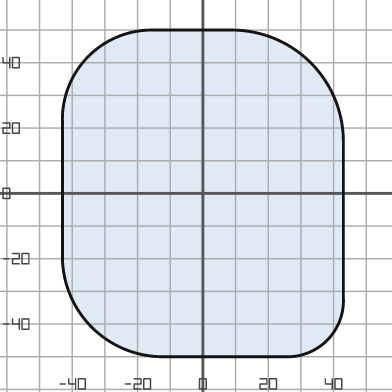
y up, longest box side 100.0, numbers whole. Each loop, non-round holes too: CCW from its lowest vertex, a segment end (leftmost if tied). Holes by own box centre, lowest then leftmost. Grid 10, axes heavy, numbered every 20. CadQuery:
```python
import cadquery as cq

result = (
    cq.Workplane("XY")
    .moveTo(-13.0, -50.0)
    .lineTo(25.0, -50.0)
    .threePointArc((38.0, -45.0), (43.0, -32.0))
    .lineTo(43.0, 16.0)
    .threePointArc((33.0, 40.0), (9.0, 50.0))
    .lineTo(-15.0, 50.0)
    .threePointArc((-35.0, 42.0), (-43.0, 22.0))
    .lineTo(-43.0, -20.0)
    .threePointArc((-34.0, -41.0), (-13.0, -50.0))
    .close()
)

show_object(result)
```